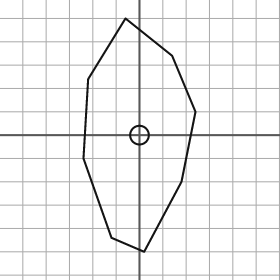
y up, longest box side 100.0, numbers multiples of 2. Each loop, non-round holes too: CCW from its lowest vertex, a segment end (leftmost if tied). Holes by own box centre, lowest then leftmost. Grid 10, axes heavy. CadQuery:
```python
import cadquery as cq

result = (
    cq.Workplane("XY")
    .moveTo(2.0, -50.0)
    .lineTo(18.0, -20.0)
    .lineTo(24.0, 10.0)
    .lineTo(14.0, 34.0)
    .lineTo(-6.0, 50.0)
    .lineTo(-22.0, 24.0)
    .lineTo(-24.0, -10.0)
    .lineTo(-12.0, -44.0)
    .close()
    .moveTo(0.0, 0.0)
    .circle(4.0)
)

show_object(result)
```